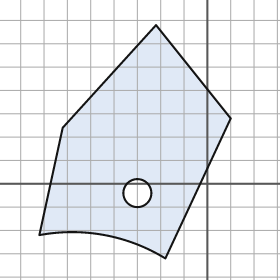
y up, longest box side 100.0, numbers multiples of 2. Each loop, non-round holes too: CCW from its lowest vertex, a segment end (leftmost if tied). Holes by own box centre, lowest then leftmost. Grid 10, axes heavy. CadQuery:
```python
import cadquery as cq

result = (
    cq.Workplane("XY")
    .moveTo(-18.0, -32.0)
    .lineTo(10.0, 28.0)
    .lineTo(-22.0, 68.0)
    .lineTo(-62.0, 24.0)
    .lineTo(-72.0, -22.0)
    .threePointArc((-44.0, -22.0), (-18.0, -32.0))
    .close()
    .moveTo(-30.0, -4.0)
    .circle(6.0)
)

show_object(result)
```